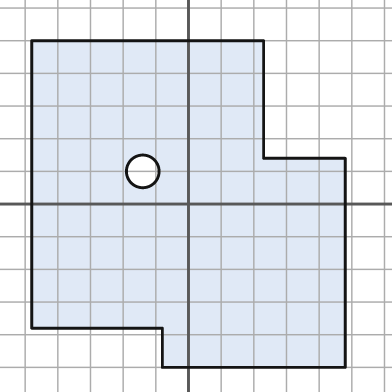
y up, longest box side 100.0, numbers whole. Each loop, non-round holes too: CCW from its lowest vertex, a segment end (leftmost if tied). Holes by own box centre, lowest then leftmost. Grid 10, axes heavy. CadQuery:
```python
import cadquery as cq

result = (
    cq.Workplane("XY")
    .moveTo(-8.0, -50.0)
    .lineTo(48.0, -50.0)
    .lineTo(48.0, 14.0)
    .lineTo(23.0, 14.0)
    .lineTo(23.0, 50.0)
    .lineTo(-48.0, 50.0)
    .lineTo(-48.0, -38.0)
    .lineTo(-8.0, -38.0)
    .close()
    .moveTo(-14.0, 10.0)
    .circle(5.0)
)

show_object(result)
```